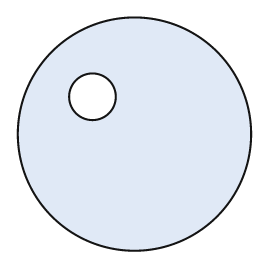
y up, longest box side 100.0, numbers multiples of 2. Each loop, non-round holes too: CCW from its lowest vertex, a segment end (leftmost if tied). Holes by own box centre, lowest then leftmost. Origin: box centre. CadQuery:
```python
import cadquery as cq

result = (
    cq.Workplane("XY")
    .moveTo(0.0, 0.0)
    .circle(50.0)
    .moveTo(-18.0, 16.0)
    .circle(10.0)
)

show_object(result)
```